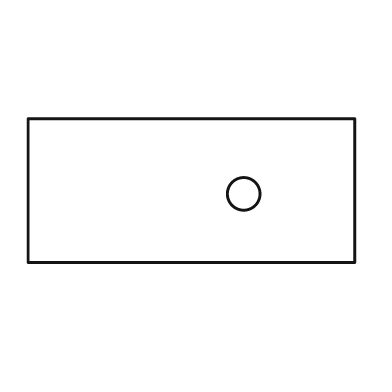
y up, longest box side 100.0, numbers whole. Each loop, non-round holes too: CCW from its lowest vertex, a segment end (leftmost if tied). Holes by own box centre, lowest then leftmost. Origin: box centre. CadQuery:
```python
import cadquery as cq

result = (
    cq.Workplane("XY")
    .moveTo(-50.0, -22.0)
    .lineTo(50.0, -22.0)
    .lineTo(50.0, 22.0)
    .lineTo(-50.0, 22.0)
    .close()
    .moveTo(16.0, -1.0)
    .circle(5.0)
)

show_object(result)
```